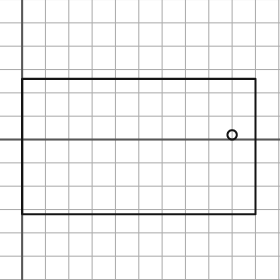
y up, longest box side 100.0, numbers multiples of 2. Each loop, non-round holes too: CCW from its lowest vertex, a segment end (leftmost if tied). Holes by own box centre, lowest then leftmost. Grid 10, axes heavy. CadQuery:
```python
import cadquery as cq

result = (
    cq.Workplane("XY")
    .moveTo(0.0, -32.0)
    .lineTo(100.0, -32.0)
    .lineTo(100.0, 26.0)
    .lineTo(0.0, 26.0)
    .close()
    .moveTo(90.0, 2.0)
    .circle(2.0)
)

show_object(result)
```